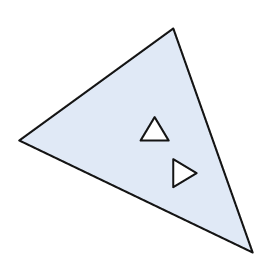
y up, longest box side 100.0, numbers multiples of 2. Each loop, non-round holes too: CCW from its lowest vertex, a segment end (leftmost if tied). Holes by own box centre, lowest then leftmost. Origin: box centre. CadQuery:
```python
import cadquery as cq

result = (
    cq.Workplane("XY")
    .moveTo(50.0, -48.0)
    .lineTo(16.0, 48.0)
    .lineTo(-50.0, 0.0)
    .close()
    .moveTo(16.0, -20.0)
    .lineTo(26.0, -14.0)
    .lineTo(16.0, -8.0)
    .close()
    .moveTo(2.0, 0.0)
    .lineTo(14.0, 0.0)
    .lineTo(8.0, 10.0)
    .close()
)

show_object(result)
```